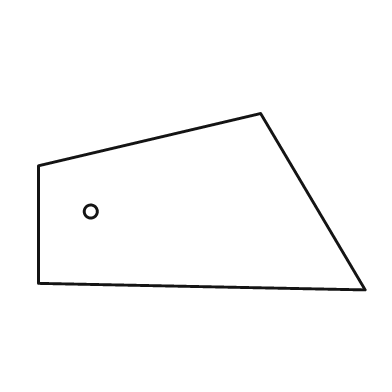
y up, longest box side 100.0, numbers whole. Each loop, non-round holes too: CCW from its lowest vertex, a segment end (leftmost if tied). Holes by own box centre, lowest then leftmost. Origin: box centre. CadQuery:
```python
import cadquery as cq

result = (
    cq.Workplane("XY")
    .moveTo(50.0, -27.0)
    .lineTo(18.0, 27.0)
    .lineTo(-50.0, 11.0)
    .lineTo(-50.0, -25.0)
    .close()
    .moveTo(-34.0, -3.0)
    .circle(2.0)
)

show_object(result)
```